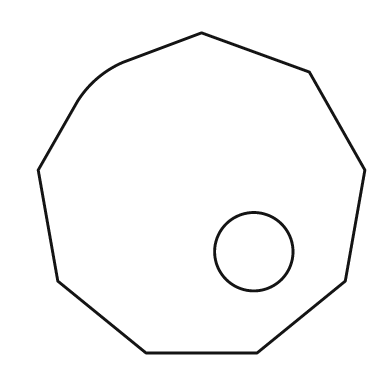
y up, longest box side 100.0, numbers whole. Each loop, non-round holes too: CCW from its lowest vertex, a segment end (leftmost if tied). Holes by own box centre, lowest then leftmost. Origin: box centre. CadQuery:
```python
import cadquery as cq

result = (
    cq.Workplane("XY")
    .moveTo(-17.0, -49.0)
    .lineTo(17.0, -49.0)
    .lineTo(44.0, -27.0)
    .lineTo(50.0, 7.0)
    .lineTo(33.0, 37.0)
    .lineTo(0.0, 49.0)
    .lineTo(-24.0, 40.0)
    .threePointArc((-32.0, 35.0), (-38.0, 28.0))
    .lineTo(-50.0, 7.0)
    .lineTo(-44.0, -27.0)
    .close()
    .moveTo(16.0, -18.0)
    .circle(12.0)
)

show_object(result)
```